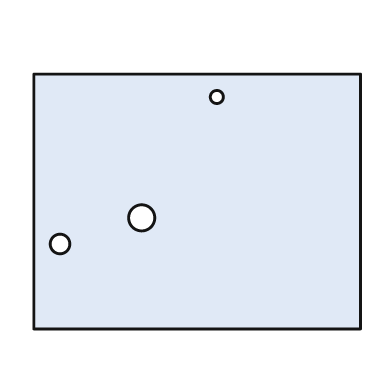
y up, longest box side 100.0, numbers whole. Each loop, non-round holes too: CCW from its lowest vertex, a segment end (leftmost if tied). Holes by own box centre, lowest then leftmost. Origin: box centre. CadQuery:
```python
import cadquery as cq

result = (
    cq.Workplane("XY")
    .moveTo(-50.0, -39.0)
    .lineTo(50.0, -39.0)
    .lineTo(50.0, 39.0)
    .lineTo(-50.0, 39.0)
    .close()
    .moveTo(-42.0, -13.0)
    .circle(3.0)
    .moveTo(-17.0, -5.0)
    .circle(4.0)
    .moveTo(6.0, 32.0)
    .circle(2.0)
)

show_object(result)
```